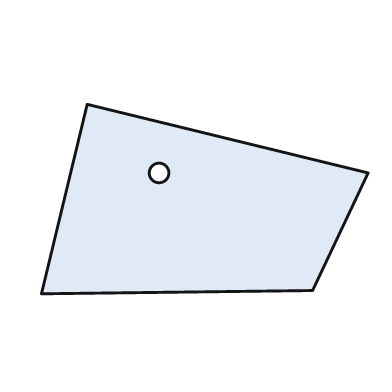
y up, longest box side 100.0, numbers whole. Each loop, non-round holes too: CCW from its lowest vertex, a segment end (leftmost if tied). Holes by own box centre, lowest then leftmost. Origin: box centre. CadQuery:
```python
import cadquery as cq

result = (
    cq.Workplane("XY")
    .moveTo(-50.0, -29.0)
    .lineTo(33.0, -28.0)
    .lineTo(50.0, 8.0)
    .lineTo(-36.0, 29.0)
    .close()
    .moveTo(-14.0, 8.0)
    .circle(3.0)
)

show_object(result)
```